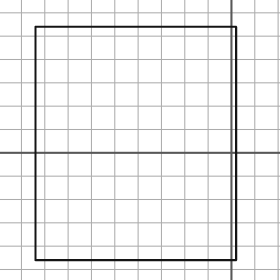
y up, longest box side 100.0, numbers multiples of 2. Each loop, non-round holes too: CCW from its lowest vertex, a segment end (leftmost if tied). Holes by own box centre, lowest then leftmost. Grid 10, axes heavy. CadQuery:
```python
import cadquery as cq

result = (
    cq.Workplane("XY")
    .moveTo(-84.0, -46.0)
    .lineTo(2.0, -46.0)
    .lineTo(2.0, 54.0)
    .lineTo(-84.0, 54.0)
    .close()
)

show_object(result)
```